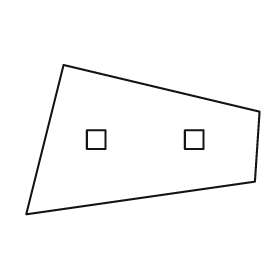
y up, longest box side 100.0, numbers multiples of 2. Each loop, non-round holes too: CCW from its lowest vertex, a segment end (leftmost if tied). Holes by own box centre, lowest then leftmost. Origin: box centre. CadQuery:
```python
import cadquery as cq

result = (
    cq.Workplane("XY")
    .moveTo(-50.0, -32.0)
    .lineTo(48.0, -18.0)
    .lineTo(50.0, 12.0)
    .lineTo(-34.0, 32.0)
    .close()
    .moveTo(-24.0, -4.0)
    .lineTo(-16.0, -4.0)
    .lineTo(-16.0, 4.0)
    .lineTo(-24.0, 4.0)
    .close()
    .moveTo(18.0, -4.0)
    .lineTo(26.0, -4.0)
    .lineTo(26.0, 4.0)
    .lineTo(18.0, 4.0)
    .close()
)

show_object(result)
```